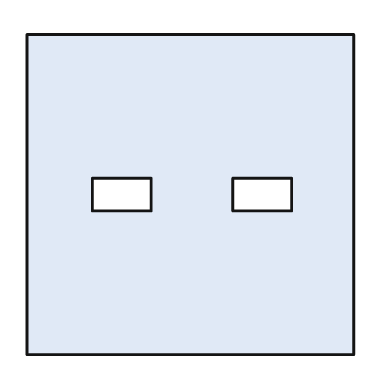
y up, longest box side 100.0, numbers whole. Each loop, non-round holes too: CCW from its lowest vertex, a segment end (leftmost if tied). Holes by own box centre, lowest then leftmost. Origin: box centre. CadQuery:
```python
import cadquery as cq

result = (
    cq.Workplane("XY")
    .moveTo(-50.0, -49.0)
    .lineTo(50.0, -49.0)
    .lineTo(50.0, 49.0)
    .lineTo(-50.0, 49.0)
    .close()
    .moveTo(-30.0, -5.0)
    .lineTo(-12.0, -5.0)
    .lineTo(-12.0, 5.0)
    .lineTo(-30.0, 5.0)
    .close()
    .moveTo(13.0, -5.0)
    .lineTo(31.0, -5.0)
    .lineTo(31.0, 5.0)
    .lineTo(13.0, 5.0)
    .close()
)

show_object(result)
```